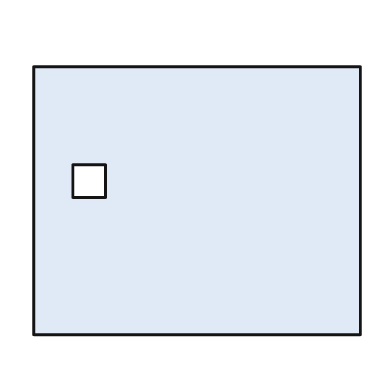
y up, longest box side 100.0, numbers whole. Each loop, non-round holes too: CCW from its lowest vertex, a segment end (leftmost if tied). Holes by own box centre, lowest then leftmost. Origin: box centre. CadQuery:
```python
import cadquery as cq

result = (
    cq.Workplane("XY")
    .moveTo(-50.0, -41.0)
    .lineTo(50.0, -41.0)
    .lineTo(50.0, 41.0)
    .lineTo(-50.0, 41.0)
    .close()
    .moveTo(-38.0, 1.0)
    .lineTo(-28.0, 1.0)
    .lineTo(-28.0, 11.0)
    .lineTo(-38.0, 11.0)
    .close()
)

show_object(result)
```